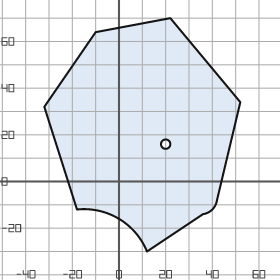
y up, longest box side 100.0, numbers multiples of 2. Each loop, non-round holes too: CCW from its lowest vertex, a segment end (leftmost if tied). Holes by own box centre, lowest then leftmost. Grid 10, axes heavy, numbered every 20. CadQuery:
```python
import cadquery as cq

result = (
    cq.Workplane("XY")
    .moveTo(12.0, -30.0)
    .lineTo(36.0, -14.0)
    .threePointArc((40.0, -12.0), (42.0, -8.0))
    .lineTo(52.0, 34.0)
    .lineTo(22.0, 70.0)
    .lineTo(-10.0, 64.0)
    .lineTo(-32.0, 32.0)
    .lineTo(-18.0, -12.0)
    .threePointArc((0.0, -16.0), (12.0, -30.0))
    .close()
    .moveTo(20.0, 16.0)
    .circle(2.0)
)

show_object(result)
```